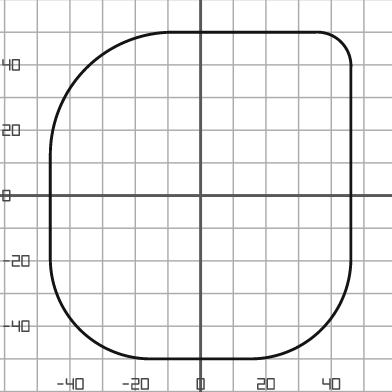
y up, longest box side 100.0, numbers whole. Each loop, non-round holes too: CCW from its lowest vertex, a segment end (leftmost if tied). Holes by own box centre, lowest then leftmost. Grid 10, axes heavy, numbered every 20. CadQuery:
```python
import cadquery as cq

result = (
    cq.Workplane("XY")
    .moveTo(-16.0, -50.0)
    .lineTo(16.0, -50.0)
    .threePointArc((37.0, -41.0), (46.0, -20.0))
    .lineTo(46.0, 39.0)
    .threePointArc((43.0, 47.0), (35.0, 50.0))
    .lineTo(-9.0, 50.0)
    .threePointArc((-35.0, 39.0), (-46.0, 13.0))
    .lineTo(-46.0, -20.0)
    .threePointArc((-37.0, -41.0), (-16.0, -50.0))
    .close()
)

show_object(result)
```